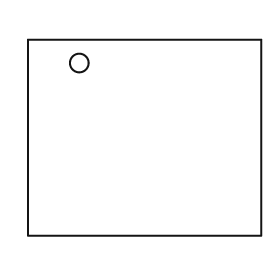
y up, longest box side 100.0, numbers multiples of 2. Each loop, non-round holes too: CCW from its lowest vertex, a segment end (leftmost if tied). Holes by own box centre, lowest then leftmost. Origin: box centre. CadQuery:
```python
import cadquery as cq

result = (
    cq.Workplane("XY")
    .moveTo(-50.0, -42.0)
    .lineTo(50.0, -42.0)
    .lineTo(50.0, 42.0)
    .lineTo(-50.0, 42.0)
    .close()
    .moveTo(-28.0, 32.0)
    .circle(4.0)
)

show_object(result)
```